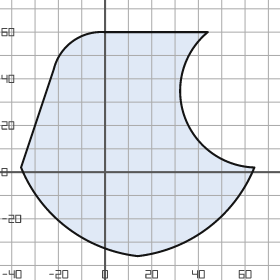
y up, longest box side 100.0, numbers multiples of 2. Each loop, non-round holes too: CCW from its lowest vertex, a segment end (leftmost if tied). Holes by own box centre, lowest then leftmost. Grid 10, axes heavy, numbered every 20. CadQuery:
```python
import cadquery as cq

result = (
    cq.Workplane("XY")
    .moveTo(14.0, -36.0)
    .threePointArc((44.0, -24.0), (64.0, 2.0))
    .threePointArc((34.0, 24.0), (44.0, 60.0))
    .lineTo(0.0, 60.0)
    .threePointArc((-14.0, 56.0), (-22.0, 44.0))
    .lineTo(-36.0, 2.0)
    .threePointArc((-16.0, -24.0), (14.0, -36.0))
    .close()
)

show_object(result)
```